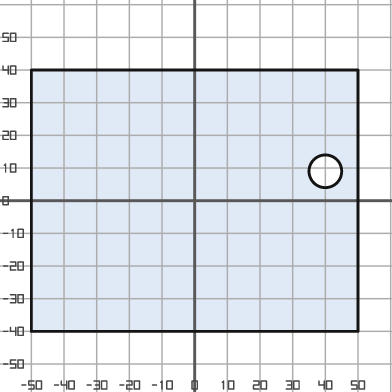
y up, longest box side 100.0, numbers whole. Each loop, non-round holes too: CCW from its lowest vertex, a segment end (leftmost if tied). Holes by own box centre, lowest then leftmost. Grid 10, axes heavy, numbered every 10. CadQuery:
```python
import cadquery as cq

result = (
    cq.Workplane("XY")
    .moveTo(-50.0, -40.0)
    .lineTo(50.0, -40.0)
    .lineTo(50.0, 40.0)
    .lineTo(-50.0, 40.0)
    .close()
    .moveTo(40.0, 9.0)
    .circle(5.0)
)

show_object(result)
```